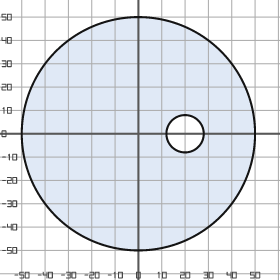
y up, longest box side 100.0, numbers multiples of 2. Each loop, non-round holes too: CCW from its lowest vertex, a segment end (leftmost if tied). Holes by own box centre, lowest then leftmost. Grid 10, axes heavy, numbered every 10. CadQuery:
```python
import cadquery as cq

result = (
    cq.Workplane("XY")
    .moveTo(0.0, 0.0)
    .circle(50.0)
    .moveTo(20.0, 0.0)
    .circle(8.0)
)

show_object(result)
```